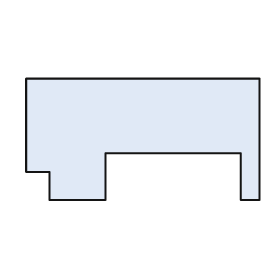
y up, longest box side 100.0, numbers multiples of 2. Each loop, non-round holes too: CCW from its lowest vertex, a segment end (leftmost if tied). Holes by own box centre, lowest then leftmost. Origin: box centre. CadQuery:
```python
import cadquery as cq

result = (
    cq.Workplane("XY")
    .moveTo(-40.0, -26.0)
    .lineTo(-16.0, -26.0)
    .lineTo(-16.0, -6.0)
    .lineTo(42.0, -6.0)
    .lineTo(42.0, -26.0)
    .lineTo(50.0, -26.0)
    .lineTo(50.0, 26.0)
    .lineTo(-50.0, 26.0)
    .lineTo(-50.0, -14.0)
    .lineTo(-40.0, -14.0)
    .close()
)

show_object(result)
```